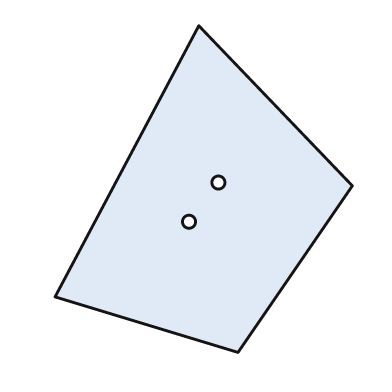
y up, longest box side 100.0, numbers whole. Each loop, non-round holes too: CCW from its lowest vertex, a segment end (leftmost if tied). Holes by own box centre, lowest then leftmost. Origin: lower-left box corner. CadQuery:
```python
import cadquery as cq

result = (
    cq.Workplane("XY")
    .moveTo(56.0, 0.0)
    .lineTo(91.0, 51.0)
    .lineTo(44.0, 100.0)
    .lineTo(0.0, 17.0)
    .close()
    .moveTo(41.0, 40.0)
    .circle(2.0)
    .moveTo(50.0, 52.0)
    .circle(2.0)
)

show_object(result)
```